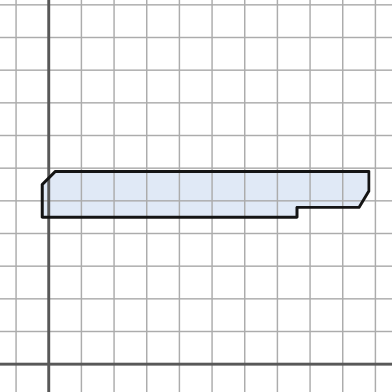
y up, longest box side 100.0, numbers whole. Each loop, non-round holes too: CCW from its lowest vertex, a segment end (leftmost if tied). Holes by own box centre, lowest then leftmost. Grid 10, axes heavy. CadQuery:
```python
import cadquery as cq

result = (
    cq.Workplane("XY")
    .moveTo(-2.0, 45.0)
    .lineTo(76.0, 45.0)
    .lineTo(76.0, 48.0)
    .lineTo(95.0, 48.0)
    .lineTo(98.0, 53.0)
    .lineTo(98.0, 59.0)
    .lineTo(2.0, 59.0)
    .lineTo(-2.0, 55.0)
    .close()
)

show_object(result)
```